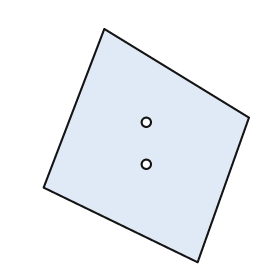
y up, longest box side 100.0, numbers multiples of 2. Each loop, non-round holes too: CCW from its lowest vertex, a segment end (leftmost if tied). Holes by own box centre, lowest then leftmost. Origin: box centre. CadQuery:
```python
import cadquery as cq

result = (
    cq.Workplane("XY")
    .moveTo(22.0, -50.0)
    .lineTo(44.0, 12.0)
    .lineTo(-18.0, 50.0)
    .lineTo(-44.0, -18.0)
    .close()
    .moveTo(0.0, -8.0)
    .circle(2.0)
    .moveTo(0.0, 10.0)
    .circle(2.0)
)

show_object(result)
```